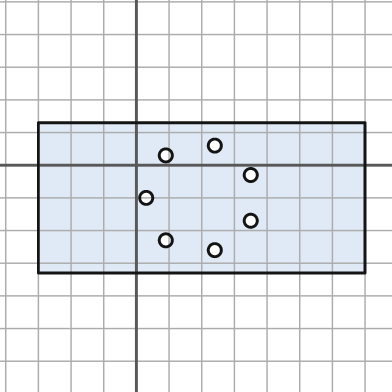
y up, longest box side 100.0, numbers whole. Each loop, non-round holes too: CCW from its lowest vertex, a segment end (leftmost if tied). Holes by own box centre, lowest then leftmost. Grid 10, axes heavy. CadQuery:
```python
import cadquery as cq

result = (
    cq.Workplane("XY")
    .moveTo(-30.0, -33.0)
    .lineTo(70.0, -33.0)
    .lineTo(70.0, 13.0)
    .lineTo(-30.0, 13.0)
    .close()
    .moveTo(24.0, -26.0)
    .circle(2.0)
    .moveTo(9.0, -23.0)
    .circle(2.0)
    .moveTo(35.0, -17.0)
    .circle(2.0)
    .moveTo(3.0, -10.0)
    .circle(2.0)
    .moveTo(35.0, -3.0)
    .circle(2.0)
    .moveTo(9.0, 3.0)
    .circle(2.0)
    .moveTo(24.0, 6.0)
    .circle(2.0)
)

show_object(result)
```